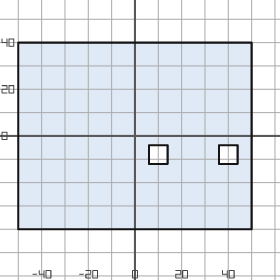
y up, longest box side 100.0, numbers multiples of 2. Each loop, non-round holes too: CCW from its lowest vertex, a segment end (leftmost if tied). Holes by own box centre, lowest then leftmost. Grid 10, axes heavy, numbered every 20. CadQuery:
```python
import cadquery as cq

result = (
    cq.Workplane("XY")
    .moveTo(-50.0, -40.0)
    .lineTo(50.0, -40.0)
    .lineTo(50.0, 40.0)
    .lineTo(-50.0, 40.0)
    .close()
    .moveTo(6.0, -12.0)
    .lineTo(14.0, -12.0)
    .lineTo(14.0, -4.0)
    .lineTo(6.0, -4.0)
    .close()
    .moveTo(36.0, -12.0)
    .lineTo(44.0, -12.0)
    .lineTo(44.0, -4.0)
    .lineTo(36.0, -4.0)
    .close()
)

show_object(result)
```